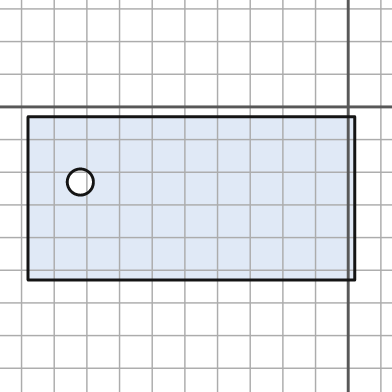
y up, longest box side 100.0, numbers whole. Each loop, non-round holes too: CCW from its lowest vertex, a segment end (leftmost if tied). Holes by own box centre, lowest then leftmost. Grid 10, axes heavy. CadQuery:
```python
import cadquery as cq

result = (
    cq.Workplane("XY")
    .moveTo(-98.0, -53.0)
    .lineTo(2.0, -53.0)
    .lineTo(2.0, -3.0)
    .lineTo(-98.0, -3.0)
    .close()
    .moveTo(-82.0, -23.0)
    .circle(4.0)
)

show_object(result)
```